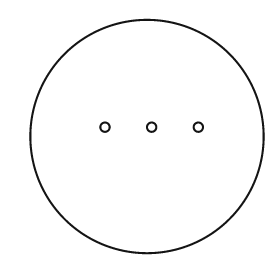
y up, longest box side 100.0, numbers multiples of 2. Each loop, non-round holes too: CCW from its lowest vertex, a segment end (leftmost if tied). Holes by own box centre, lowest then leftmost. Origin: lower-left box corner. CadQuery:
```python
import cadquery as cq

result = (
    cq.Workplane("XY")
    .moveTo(50.0, 50.0)
    .circle(50.0)
    .moveTo(32.0, 54.0)
    .circle(2.0)
    .moveTo(52.0, 54.0)
    .circle(2.0)
    .moveTo(72.0, 54.0)
    .circle(2.0)
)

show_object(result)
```